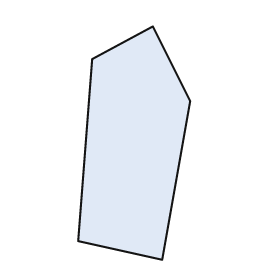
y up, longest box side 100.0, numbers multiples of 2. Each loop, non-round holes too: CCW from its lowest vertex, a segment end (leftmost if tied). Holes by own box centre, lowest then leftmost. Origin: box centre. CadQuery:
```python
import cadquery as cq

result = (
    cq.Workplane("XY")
    .moveTo(12.0, -50.0)
    .lineTo(24.0, 18.0)
    .lineTo(8.0, 50.0)
    .lineTo(-18.0, 36.0)
    .lineTo(-24.0, -42.0)
    .close()
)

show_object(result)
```